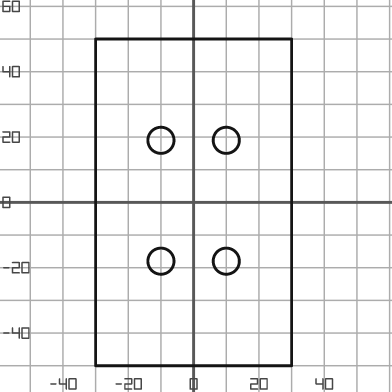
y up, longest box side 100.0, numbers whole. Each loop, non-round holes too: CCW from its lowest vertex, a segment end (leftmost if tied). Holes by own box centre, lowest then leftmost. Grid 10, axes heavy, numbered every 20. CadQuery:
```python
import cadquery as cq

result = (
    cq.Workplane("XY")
    .moveTo(-30.0, -50.0)
    .lineTo(30.0, -50.0)
    .lineTo(30.0, 50.0)
    .lineTo(-30.0, 50.0)
    .close()
    .moveTo(-10.0, -18.0)
    .circle(4.0)
    .moveTo(10.0, -18.0)
    .circle(4.0)
    .moveTo(-10.0, 19.0)
    .circle(4.0)
    .moveTo(10.0, 19.0)
    .circle(4.0)
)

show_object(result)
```